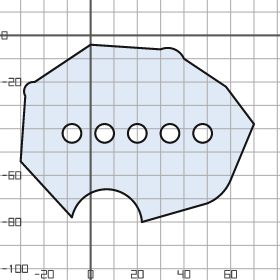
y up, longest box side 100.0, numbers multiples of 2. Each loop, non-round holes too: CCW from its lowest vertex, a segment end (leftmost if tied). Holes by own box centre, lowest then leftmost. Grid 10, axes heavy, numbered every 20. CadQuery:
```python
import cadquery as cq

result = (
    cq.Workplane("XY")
    .moveTo(22.0, -80.0)
    .lineTo(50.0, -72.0)
    .threePointArc((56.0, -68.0), (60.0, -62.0))
    .lineTo(70.0, -38.0)
    .lineTo(58.0, -22.0)
    .lineTo(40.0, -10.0)
    .threePointArc((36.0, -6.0), (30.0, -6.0))
    .lineTo(0.0, -4.0)
    .lineTo(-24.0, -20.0)
    .threePointArc((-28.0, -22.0), (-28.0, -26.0))
    .lineTo(-30.0, -54.0)
    .lineTo(-8.0, -78.0)
    .threePointArc((8.0, -66.0), (22.0, -80.0))
    .close()
    .moveTo(-8.0, -42.0)
    .circle(4.0)
    .moveTo(6.0, -42.0)
    .circle(4.0)
    .moveTo(20.0, -42.0)
    .circle(4.0)
    .moveTo(34.0, -42.0)
    .circle(4.0)
    .moveTo(48.0, -42.0)
    .circle(4.0)
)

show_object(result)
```